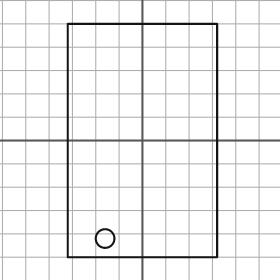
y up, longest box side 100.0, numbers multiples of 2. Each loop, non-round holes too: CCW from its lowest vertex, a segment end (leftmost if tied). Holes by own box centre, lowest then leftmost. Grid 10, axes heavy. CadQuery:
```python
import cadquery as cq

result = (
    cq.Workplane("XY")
    .moveTo(-32.0, -50.0)
    .lineTo(32.0, -50.0)
    .lineTo(32.0, 50.0)
    .lineTo(-32.0, 50.0)
    .close()
    .moveTo(-16.0, -42.0)
    .circle(4.0)
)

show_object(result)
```